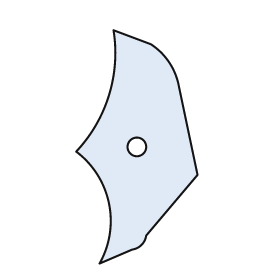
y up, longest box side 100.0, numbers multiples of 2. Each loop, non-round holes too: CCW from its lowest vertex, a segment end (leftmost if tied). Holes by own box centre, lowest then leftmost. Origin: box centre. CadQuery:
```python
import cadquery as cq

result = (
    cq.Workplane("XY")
    .moveTo(-16.0, -50.0)
    .lineTo(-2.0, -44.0)
    .threePointArc((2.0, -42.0), (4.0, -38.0))
    .lineTo(26.0, -12.0)
    .lineTo(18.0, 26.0)
    .threePointArc((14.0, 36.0), (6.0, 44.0))
    .lineTo(-10.0, 50.0)
    .threePointArc((-12.0, 22.0), (-26.0, -2.0))
    .threePointArc((-12.0, -24.0), (-16.0, -50.0))
    .close()
    .moveTo(0.0, 0.0)
    .circle(4.0)
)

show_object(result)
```